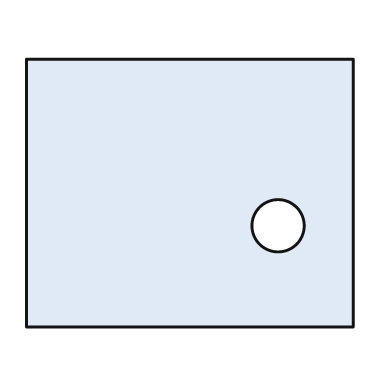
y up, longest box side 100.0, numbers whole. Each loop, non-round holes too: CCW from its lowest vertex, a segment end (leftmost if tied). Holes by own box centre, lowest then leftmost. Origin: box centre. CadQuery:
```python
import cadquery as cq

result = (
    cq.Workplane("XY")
    .moveTo(-50.0, -41.0)
    .lineTo(50.0, -41.0)
    .lineTo(50.0, 41.0)
    .lineTo(-50.0, 41.0)
    .close()
    .moveTo(27.0, -10.0)
    .circle(8.0)
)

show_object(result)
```